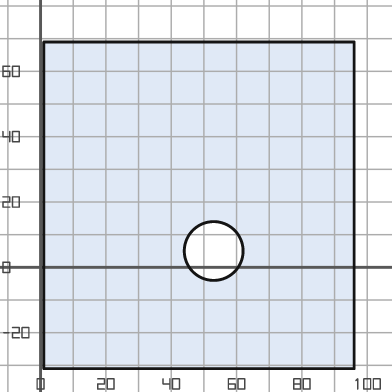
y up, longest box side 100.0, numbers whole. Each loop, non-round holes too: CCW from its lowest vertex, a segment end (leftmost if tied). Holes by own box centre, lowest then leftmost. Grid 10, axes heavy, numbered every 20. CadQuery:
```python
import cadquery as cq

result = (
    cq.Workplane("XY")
    .moveTo(1.0, -31.0)
    .lineTo(96.0, -31.0)
    .lineTo(96.0, 69.0)
    .lineTo(1.0, 69.0)
    .close()
    .moveTo(53.0, 5.0)
    .circle(9.0)
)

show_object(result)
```